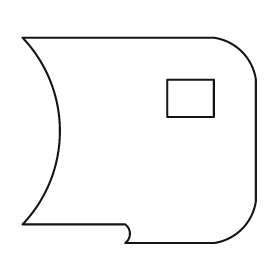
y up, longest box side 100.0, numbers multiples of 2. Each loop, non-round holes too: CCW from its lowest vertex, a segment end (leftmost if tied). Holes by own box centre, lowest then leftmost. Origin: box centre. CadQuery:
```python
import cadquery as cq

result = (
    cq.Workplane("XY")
    .moveTo(-6.0, -44.0)
    .lineTo(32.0, -44.0)
    .threePointArc((44.0, -38.0), (50.0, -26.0))
    .lineTo(50.0, 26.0)
    .threePointArc((44.0, 38.0), (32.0, 44.0))
    .lineTo(-50.0, 44.0)
    .threePointArc((-34.0, 4.0), (-50.0, -36.0))
    .lineTo(-6.0, -36.0)
    .threePointArc((-4.0, -40.0), (-6.0, -44.0))
    .close()
    .moveTo(12.0, 10.0)
    .lineTo(32.0, 10.0)
    .lineTo(32.0, 26.0)
    .lineTo(12.0, 26.0)
    .close()
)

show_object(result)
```